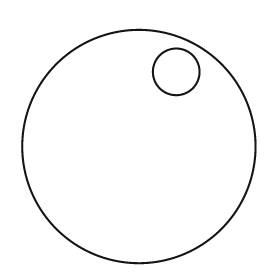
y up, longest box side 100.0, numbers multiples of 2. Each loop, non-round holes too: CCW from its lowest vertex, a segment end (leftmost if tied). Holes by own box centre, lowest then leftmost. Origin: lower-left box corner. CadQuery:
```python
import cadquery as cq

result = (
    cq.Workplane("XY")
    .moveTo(50.0, 50.0)
    .circle(50.0)
    .moveTo(66.0, 82.0)
    .circle(10.0)
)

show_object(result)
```